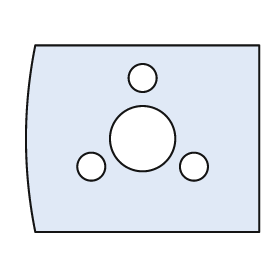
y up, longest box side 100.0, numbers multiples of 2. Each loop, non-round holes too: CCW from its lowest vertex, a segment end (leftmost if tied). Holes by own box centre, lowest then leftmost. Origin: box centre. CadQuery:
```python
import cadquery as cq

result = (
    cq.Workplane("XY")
    .moveTo(-46.0, -40.0)
    .lineTo(50.0, -40.0)
    .lineTo(50.0, 40.0)
    .lineTo(-46.0, 40.0)
    .threePointArc((-50.0, 0.0), (-46.0, -40.0))
    .close()
    .moveTo(-22.0, -12.0)
    .circle(6.0)
    .moveTo(22.0, -12.0)
    .circle(6.0)
    .moveTo(0.0, 0.0)
    .circle(14.0)
    .moveTo(0.0, 26.0)
    .circle(6.0)
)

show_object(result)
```